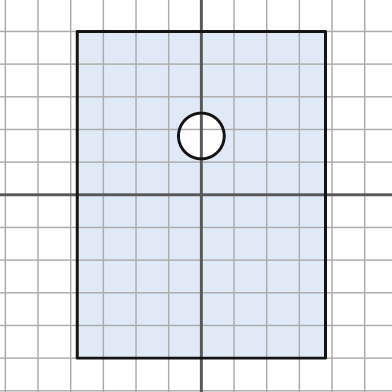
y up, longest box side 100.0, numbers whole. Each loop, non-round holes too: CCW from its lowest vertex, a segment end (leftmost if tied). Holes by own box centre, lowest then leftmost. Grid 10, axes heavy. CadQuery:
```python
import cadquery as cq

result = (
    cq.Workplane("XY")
    .moveTo(-38.0, -50.0)
    .lineTo(38.0, -50.0)
    .lineTo(38.0, 50.0)
    .lineTo(-38.0, 50.0)
    .close()
    .moveTo(0.0, 18.0)
    .circle(7.0)
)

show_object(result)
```